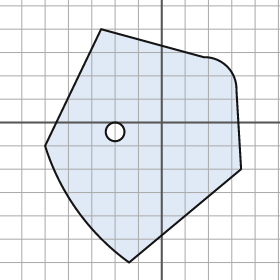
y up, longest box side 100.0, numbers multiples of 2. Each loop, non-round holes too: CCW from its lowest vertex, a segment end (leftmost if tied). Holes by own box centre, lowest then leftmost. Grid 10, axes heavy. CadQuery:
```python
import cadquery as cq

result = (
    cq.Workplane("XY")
    .moveTo(-14.0, -60.0)
    .lineTo(34.0, -20.0)
    .lineTo(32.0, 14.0)
    .threePointArc((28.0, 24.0), (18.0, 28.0))
    .lineTo(-26.0, 40.0)
    .lineTo(-50.0, -10.0)
    .threePointArc((-36.0, -38.0), (-14.0, -60.0))
    .close()
    .moveTo(-20.0, -4.0)
    .circle(4.0)
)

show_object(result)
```